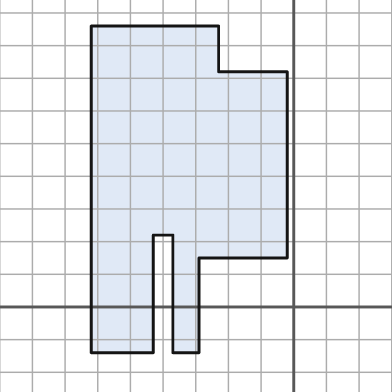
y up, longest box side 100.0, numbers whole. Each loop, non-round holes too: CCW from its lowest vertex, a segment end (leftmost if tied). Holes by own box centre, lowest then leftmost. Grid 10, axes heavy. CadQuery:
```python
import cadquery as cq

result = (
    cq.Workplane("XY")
    .moveTo(-62.0, -14.0)
    .lineTo(-43.0, -14.0)
    .lineTo(-43.0, 22.0)
    .lineTo(-37.0, 22.0)
    .lineTo(-37.0, -14.0)
    .lineTo(-29.0, -14.0)
    .lineTo(-29.0, 15.0)
    .lineTo(-2.0, 15.0)
    .lineTo(-2.0, 72.0)
    .lineTo(-23.0, 72.0)
    .lineTo(-23.0, 86.0)
    .lineTo(-62.0, 86.0)
    .close()
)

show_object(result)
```